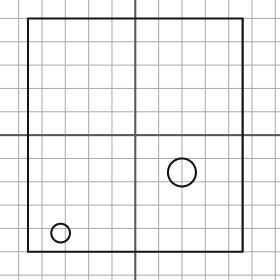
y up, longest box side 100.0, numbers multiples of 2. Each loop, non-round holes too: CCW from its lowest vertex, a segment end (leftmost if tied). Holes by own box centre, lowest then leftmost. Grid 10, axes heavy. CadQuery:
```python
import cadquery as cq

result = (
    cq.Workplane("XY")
    .moveTo(-46.0, -50.0)
    .lineTo(46.0, -50.0)
    .lineTo(46.0, 50.0)
    .lineTo(-46.0, 50.0)
    .close()
    .moveTo(-32.0, -42.0)
    .circle(4.0)
    .moveTo(20.0, -16.0)
    .circle(6.0)
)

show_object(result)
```